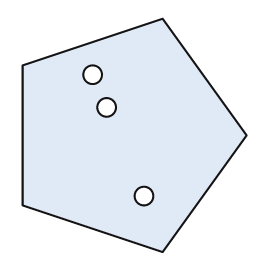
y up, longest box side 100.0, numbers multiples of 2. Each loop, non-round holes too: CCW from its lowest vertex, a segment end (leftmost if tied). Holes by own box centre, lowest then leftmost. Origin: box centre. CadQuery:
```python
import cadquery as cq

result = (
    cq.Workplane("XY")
    .moveTo(12.0, -50.0)
    .lineTo(48.0, 0.0)
    .lineTo(12.0, 50.0)
    .lineTo(-48.0, 30.0)
    .lineTo(-48.0, -30.0)
    .close()
    .moveTo(4.0, -26.0)
    .circle(4.0)
    .moveTo(-12.0, 12.0)
    .circle(4.0)
    .moveTo(-18.0, 26.0)
    .circle(4.0)
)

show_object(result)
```